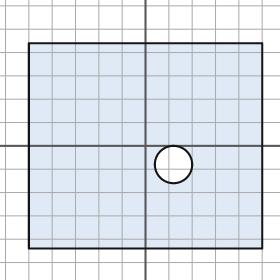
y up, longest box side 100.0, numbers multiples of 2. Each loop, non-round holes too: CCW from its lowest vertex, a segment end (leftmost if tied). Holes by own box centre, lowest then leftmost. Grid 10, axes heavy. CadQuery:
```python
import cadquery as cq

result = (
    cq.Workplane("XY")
    .moveTo(-50.0, -44.0)
    .lineTo(50.0, -44.0)
    .lineTo(50.0, 44.0)
    .lineTo(-50.0, 44.0)
    .close()
    .moveTo(12.0, -8.0)
    .circle(8.0)
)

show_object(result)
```